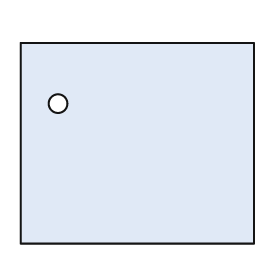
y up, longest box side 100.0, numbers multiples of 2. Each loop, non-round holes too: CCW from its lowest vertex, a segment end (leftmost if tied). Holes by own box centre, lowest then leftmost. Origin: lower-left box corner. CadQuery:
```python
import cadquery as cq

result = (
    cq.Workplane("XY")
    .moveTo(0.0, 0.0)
    .lineTo(100.0, 0.0)
    .lineTo(100.0, 86.0)
    .lineTo(0.0, 86.0)
    .close()
    .moveTo(16.0, 60.0)
    .circle(4.0)
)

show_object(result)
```